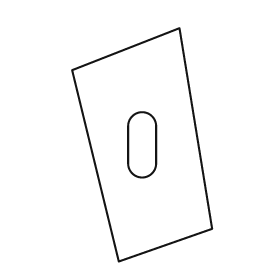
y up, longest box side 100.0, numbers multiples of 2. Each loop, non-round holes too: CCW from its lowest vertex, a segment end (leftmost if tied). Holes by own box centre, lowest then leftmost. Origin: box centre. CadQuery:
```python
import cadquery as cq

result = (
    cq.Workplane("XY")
    .moveTo(-10.0, -50.0)
    .lineTo(30.0, -36.0)
    .lineTo(16.0, 50.0)
    .lineTo(-30.0, 32.0)
    .close()
    .moveTo(-6.0, -8.0)
    .threePointArc((0.0, -14.0), (6.0, -8.0))
    .lineTo(6.0, 8.0)
    .threePointArc((0.0, 14.0), (-6.0, 8.0))
    .close()
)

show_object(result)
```